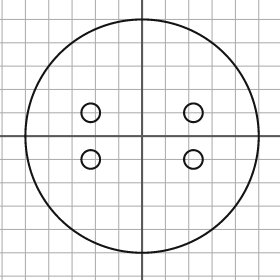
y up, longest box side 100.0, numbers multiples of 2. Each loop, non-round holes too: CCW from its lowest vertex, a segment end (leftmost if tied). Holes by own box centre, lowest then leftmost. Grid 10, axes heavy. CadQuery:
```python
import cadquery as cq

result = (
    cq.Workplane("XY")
    .moveTo(0.0, 0.0)
    .circle(50.0)
    .moveTo(-22.0, -10.0)
    .circle(4.0)
    .moveTo(22.0, -10.0)
    .circle(4.0)
    .moveTo(-22.0, 10.0)
    .circle(4.0)
    .moveTo(22.0, 10.0)
    .circle(4.0)
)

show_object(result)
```